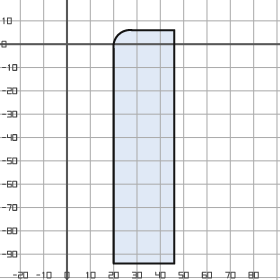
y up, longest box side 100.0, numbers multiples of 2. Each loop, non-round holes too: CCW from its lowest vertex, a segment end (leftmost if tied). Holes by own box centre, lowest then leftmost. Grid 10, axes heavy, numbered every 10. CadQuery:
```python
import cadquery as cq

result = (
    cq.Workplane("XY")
    .moveTo(20.0, -94.0)
    .lineTo(46.0, -94.0)
    .lineTo(46.0, 6.0)
    .lineTo(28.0, 6.0)
    .threePointArc((22.0, 4.0), (20.0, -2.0))
    .close()
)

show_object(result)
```